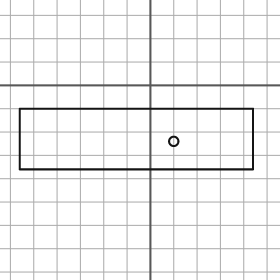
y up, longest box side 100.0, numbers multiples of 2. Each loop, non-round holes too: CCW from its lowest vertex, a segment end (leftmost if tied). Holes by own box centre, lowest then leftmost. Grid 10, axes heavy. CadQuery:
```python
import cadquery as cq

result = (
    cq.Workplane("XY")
    .moveTo(-56.0, -36.0)
    .lineTo(44.0, -36.0)
    .lineTo(44.0, -10.0)
    .lineTo(-56.0, -10.0)
    .close()
    .moveTo(10.0, -24.0)
    .circle(2.0)
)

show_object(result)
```